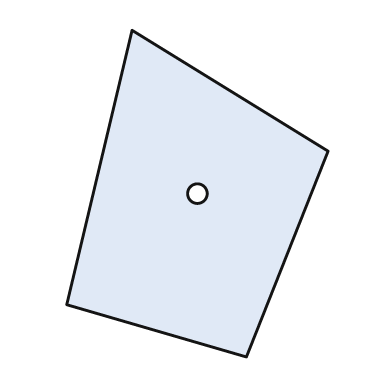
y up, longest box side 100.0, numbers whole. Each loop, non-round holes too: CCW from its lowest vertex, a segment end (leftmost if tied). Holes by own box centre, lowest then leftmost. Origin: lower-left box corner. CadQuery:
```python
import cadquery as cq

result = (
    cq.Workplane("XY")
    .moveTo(55.0, 0.0)
    .lineTo(80.0, 63.0)
    .lineTo(20.0, 100.0)
    .lineTo(0.0, 16.0)
    .close()
    .moveTo(40.0, 50.0)
    .circle(3.0)
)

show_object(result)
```